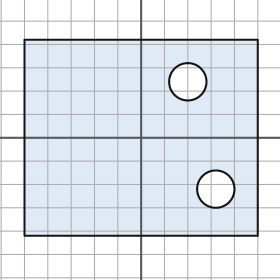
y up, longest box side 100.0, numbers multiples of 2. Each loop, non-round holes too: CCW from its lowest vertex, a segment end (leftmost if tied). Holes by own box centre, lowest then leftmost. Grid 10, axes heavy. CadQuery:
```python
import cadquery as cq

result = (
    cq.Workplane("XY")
    .moveTo(-50.0, -42.0)
    .lineTo(50.0, -42.0)
    .lineTo(50.0, 42.0)
    .lineTo(-50.0, 42.0)
    .close()
    .moveTo(32.0, -22.0)
    .circle(8.0)
    .moveTo(20.0, 24.0)
    .circle(8.0)
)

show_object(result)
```